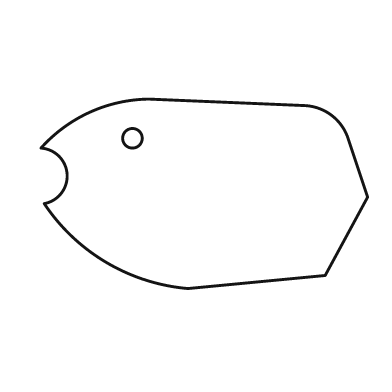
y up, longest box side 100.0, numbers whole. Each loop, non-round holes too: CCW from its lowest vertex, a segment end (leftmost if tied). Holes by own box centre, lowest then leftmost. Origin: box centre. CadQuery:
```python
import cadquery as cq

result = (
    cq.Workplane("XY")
    .moveTo(-5.0, -29.0)
    .lineTo(37.0, -25.0)
    .lineTo(50.0, -1.0)
    .lineTo(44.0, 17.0)
    .threePointArc((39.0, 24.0), (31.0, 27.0))
    .lineTo(-17.0, 29.0)
    .threePointArc((-35.0, 25.0), (-50.0, 14.0))
    .threePointArc((-42.0, 6.0), (-49.0, -3.0))
    .threePointArc((-30.0, -21.0), (-5.0, -29.0))
    .close()
    .moveTo(-22.0, 17.0)
    .circle(3.0)
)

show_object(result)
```